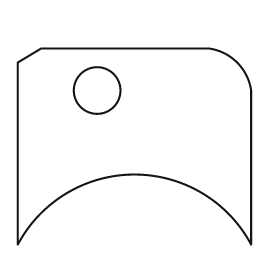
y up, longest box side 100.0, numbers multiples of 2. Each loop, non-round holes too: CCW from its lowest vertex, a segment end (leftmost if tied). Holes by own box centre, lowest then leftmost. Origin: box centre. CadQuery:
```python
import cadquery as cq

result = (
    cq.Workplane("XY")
    .moveTo(-50.0, -42.0)
    .threePointArc((0.0, -12.0), (50.0, -42.0))
    .lineTo(50.0, 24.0)
    .threePointArc((44.0, 36.0), (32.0, 42.0))
    .lineTo(-40.0, 42.0)
    .lineTo(-50.0, 36.0)
    .close()
    .moveTo(-16.0, 24.0)
    .circle(10.0)
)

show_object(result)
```